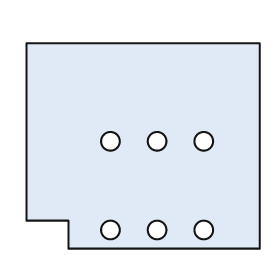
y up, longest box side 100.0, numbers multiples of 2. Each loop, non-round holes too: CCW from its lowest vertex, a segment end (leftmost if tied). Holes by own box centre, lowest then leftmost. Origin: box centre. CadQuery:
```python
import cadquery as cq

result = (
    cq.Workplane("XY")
    .moveTo(-32.0, -44.0)
    .lineTo(50.0, -44.0)
    .lineTo(50.0, 44.0)
    .lineTo(-50.0, 44.0)
    .lineTo(-50.0, -32.0)
    .lineTo(-32.0, -32.0)
    .close()
    .moveTo(-14.0, -36.0)
    .circle(4.0)
    .moveTo(6.0, -36.0)
    .circle(4.0)
    .moveTo(26.0, -36.0)
    .circle(4.0)
    .moveTo(-14.0, 2.0)
    .circle(4.0)
    .moveTo(6.0, 2.0)
    .circle(4.0)
    .moveTo(26.0, 2.0)
    .circle(4.0)
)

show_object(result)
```